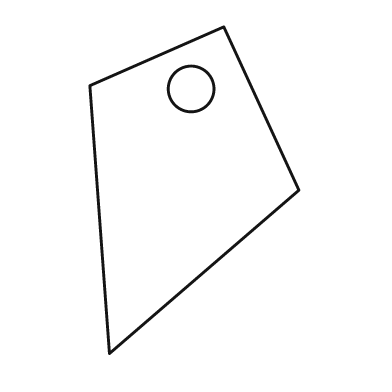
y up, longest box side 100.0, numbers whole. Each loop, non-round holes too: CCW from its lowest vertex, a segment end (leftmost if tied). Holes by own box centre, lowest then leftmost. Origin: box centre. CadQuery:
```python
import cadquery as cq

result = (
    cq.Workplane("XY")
    .moveTo(-26.0, -50.0)
    .lineTo(32.0, 0.0)
    .lineTo(9.0, 50.0)
    .lineTo(-32.0, 32.0)
    .close()
    .moveTo(-1.0, 31.0)
    .circle(7.0)
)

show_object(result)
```